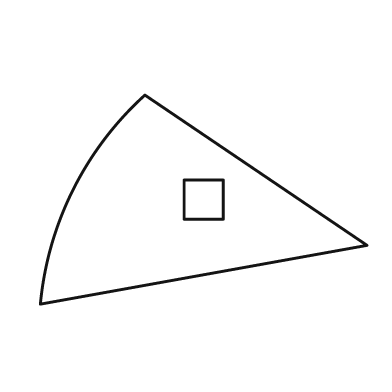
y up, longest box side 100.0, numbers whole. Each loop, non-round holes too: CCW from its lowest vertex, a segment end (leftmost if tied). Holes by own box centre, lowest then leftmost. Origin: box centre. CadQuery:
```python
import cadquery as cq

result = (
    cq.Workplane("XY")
    .moveTo(-50.0, -32.0)
    .lineTo(50.0, -14.0)
    .lineTo(-18.0, 32.0)
    .threePointArc((-40.0, 3.0), (-50.0, -32.0))
    .close()
    .moveTo(-6.0, -6.0)
    .lineTo(6.0, -6.0)
    .lineTo(6.0, 6.0)
    .lineTo(-6.0, 6.0)
    .close()
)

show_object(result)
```